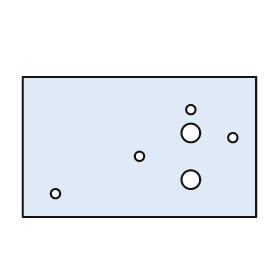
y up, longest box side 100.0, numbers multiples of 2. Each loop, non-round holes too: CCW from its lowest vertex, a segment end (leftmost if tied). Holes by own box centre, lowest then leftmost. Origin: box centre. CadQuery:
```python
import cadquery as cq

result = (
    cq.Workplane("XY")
    .moveTo(-50.0, -30.0)
    .lineTo(50.0, -30.0)
    .lineTo(50.0, 30.0)
    .lineTo(-50.0, 30.0)
    .close()
    .moveTo(-36.0, -20.0)
    .circle(2.0)
    .moveTo(22.0, -14.0)
    .circle(4.0)
    .moveTo(0.0, -4.0)
    .circle(2.0)
    .moveTo(40.0, 4.0)
    .circle(2.0)
    .moveTo(22.0, 6.0)
    .circle(4.0)
    .moveTo(22.0, 16.0)
    .circle(2.0)
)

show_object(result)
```